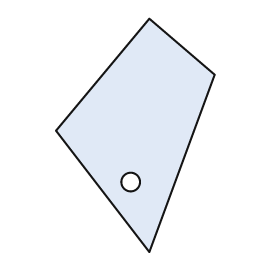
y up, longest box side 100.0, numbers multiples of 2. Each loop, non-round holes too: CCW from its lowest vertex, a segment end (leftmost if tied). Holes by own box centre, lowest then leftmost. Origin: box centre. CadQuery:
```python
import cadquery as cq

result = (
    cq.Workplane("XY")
    .moveTo(6.0, -50.0)
    .lineTo(34.0, 26.0)
    .lineTo(6.0, 50.0)
    .lineTo(-34.0, 2.0)
    .close()
    .moveTo(-2.0, -20.0)
    .circle(4.0)
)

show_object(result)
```